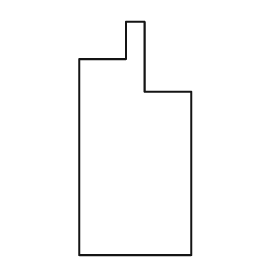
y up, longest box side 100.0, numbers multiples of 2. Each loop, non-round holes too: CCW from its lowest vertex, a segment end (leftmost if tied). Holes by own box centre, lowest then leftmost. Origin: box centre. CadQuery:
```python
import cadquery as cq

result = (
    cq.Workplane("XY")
    .moveTo(-24.0, -50.0)
    .lineTo(24.0, -50.0)
    .lineTo(24.0, 20.0)
    .lineTo(4.0, 20.0)
    .lineTo(4.0, 50.0)
    .lineTo(-4.0, 50.0)
    .lineTo(-4.0, 34.0)
    .lineTo(-24.0, 34.0)
    .close()
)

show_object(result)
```